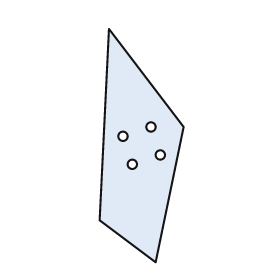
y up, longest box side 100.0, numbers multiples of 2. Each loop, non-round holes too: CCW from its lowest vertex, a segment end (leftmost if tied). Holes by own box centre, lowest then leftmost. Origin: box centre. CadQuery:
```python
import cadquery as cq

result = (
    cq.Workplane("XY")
    .moveTo(6.0, -50.0)
    .lineTo(18.0, 8.0)
    .lineTo(-14.0, 50.0)
    .lineTo(-18.0, -32.0)
    .close()
    .moveTo(-4.0, -8.0)
    .circle(2.0)
    .moveTo(8.0, -4.0)
    .circle(2.0)
    .moveTo(-8.0, 4.0)
    .circle(2.0)
    .moveTo(4.0, 8.0)
    .circle(2.0)
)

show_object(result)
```